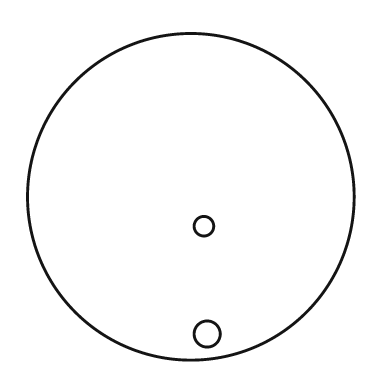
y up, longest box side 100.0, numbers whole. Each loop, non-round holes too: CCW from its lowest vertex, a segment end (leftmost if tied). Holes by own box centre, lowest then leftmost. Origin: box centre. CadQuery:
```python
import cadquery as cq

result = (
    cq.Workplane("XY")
    .moveTo(0.0, 0.0)
    .circle(50.0)
    .moveTo(5.0, -42.0)
    .circle(4.0)
    .moveTo(4.0, -9.0)
    .circle(3.0)
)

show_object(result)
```